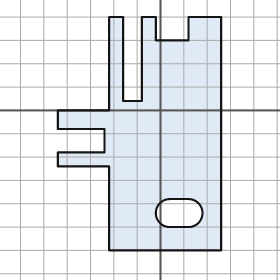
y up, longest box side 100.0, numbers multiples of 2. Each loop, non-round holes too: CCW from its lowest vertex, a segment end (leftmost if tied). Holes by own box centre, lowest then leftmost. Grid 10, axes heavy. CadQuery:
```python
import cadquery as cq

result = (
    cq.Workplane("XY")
    .moveTo(-22.0, -60.0)
    .lineTo(26.0, -60.0)
    .lineTo(26.0, 40.0)
    .lineTo(12.0, 40.0)
    .lineTo(12.0, 30.0)
    .lineTo(-2.0, 30.0)
    .lineTo(-2.0, 40.0)
    .lineTo(-8.0, 40.0)
    .lineTo(-8.0, 4.0)
    .lineTo(-16.0, 4.0)
    .lineTo(-16.0, 40.0)
    .lineTo(-22.0, 40.0)
    .lineTo(-22.0, 0.0)
    .lineTo(-44.0, 0.0)
    .lineTo(-44.0, -8.0)
    .lineTo(-24.0, -8.0)
    .lineTo(-24.0, -18.0)
    .lineTo(-44.0, -18.0)
    .lineTo(-44.0, -24.0)
    .lineTo(-22.0, -24.0)
    .close()
    .moveTo(4.0, -50.0)
    .lineTo(12.0, -50.0)
    .threePointArc((18.0, -44.0), (12.0, -38.0))
    .lineTo(4.0, -38.0)
    .threePointArc((-2.0, -44.0), (4.0, -50.0))
    .close()
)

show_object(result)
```